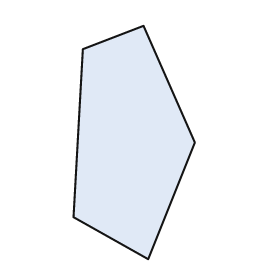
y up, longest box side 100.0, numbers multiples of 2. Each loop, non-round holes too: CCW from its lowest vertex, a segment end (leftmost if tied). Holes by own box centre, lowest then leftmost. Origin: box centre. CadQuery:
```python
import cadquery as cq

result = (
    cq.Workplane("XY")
    .moveTo(6.0, -50.0)
    .lineTo(26.0, 0.0)
    .lineTo(4.0, 50.0)
    .lineTo(-22.0, 40.0)
    .lineTo(-26.0, -32.0)
    .close()
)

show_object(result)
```